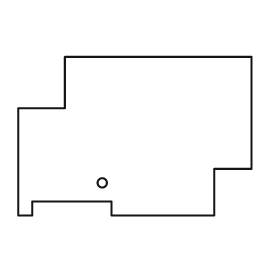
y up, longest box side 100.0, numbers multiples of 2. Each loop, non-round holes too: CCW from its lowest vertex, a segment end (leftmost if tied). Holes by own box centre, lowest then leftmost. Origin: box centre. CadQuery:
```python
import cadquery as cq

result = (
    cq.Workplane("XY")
    .moveTo(-50.0, -34.0)
    .lineTo(-44.0, -34.0)
    .lineTo(-44.0, -28.0)
    .lineTo(-10.0, -28.0)
    .lineTo(-10.0, -34.0)
    .lineTo(34.0, -34.0)
    .lineTo(34.0, -14.0)
    .lineTo(50.0, -14.0)
    .lineTo(50.0, 34.0)
    .lineTo(-30.0, 34.0)
    .lineTo(-30.0, 12.0)
    .lineTo(-50.0, 12.0)
    .close()
    .moveTo(-14.0, -20.0)
    .circle(2.0)
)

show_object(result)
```